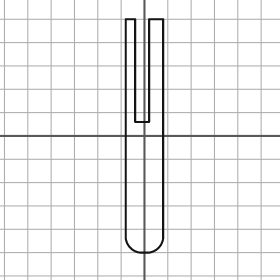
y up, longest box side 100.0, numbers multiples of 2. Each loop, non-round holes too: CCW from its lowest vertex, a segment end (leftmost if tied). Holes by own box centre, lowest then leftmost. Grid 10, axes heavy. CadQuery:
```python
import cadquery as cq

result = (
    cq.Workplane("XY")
    .moveTo(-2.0, -50.0)
    .lineTo(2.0, -50.0)
    .threePointArc((6.0, -48.0), (8.0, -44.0))
    .lineTo(8.0, 50.0)
    .lineTo(2.0, 50.0)
    .lineTo(2.0, 6.0)
    .lineTo(-4.0, 6.0)
    .lineTo(-4.0, 50.0)
    .lineTo(-8.0, 50.0)
    .lineTo(-8.0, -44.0)
    .threePointArc((-6.0, -48.0), (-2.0, -50.0))
    .close()
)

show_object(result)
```